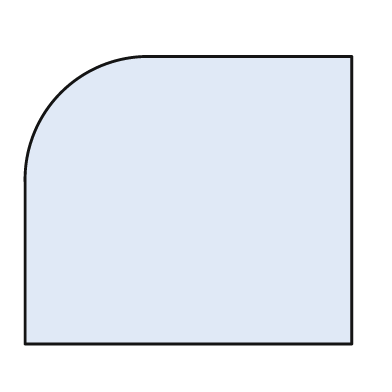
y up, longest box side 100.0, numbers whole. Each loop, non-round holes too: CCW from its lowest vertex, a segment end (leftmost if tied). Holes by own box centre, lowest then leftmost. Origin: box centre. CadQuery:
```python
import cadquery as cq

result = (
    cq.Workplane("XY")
    .moveTo(-50.0, -44.0)
    .lineTo(50.0, -44.0)
    .lineTo(50.0, 44.0)
    .lineTo(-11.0, 44.0)
    .threePointArc((-39.0, 33.0), (-50.0, 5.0))
    .close()
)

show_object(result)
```